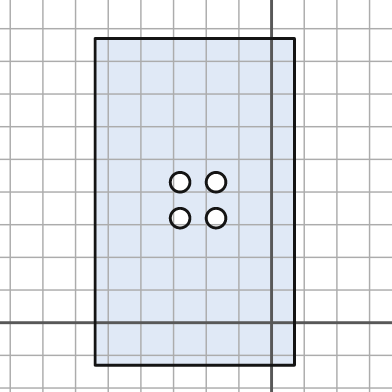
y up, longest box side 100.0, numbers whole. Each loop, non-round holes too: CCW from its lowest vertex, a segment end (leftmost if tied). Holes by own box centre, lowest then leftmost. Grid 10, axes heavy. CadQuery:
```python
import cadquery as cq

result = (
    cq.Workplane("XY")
    .moveTo(-54.0, -13.0)
    .lineTo(7.0, -13.0)
    .lineTo(7.0, 87.0)
    .lineTo(-54.0, 87.0)
    .close()
    .moveTo(-28.0, 32.0)
    .circle(3.0)
    .moveTo(-17.0, 32.0)
    .circle(3.0)
    .moveTo(-28.0, 43.0)
    .circle(3.0)
    .moveTo(-17.0, 43.0)
    .circle(3.0)
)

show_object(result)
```